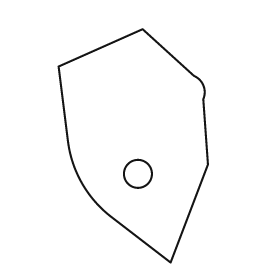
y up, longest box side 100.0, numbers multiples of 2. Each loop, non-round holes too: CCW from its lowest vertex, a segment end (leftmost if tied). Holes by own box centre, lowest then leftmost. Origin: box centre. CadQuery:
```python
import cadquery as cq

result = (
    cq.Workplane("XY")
    .moveTo(16.0, -50.0)
    .lineTo(32.0, -8.0)
    .lineTo(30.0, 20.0)
    .threePointArc((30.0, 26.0), (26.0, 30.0))
    .lineTo(4.0, 50.0)
    .lineTo(-32.0, 34.0)
    .lineTo(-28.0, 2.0)
    .threePointArc((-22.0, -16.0), (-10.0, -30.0))
    .close()
    .moveTo(2.0, -12.0)
    .circle(6.0)
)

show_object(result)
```